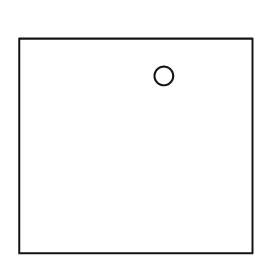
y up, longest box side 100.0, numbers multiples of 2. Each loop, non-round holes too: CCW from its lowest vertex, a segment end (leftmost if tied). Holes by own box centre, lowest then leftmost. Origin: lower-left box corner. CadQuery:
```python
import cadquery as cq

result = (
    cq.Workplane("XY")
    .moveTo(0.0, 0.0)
    .lineTo(100.0, 0.0)
    .lineTo(100.0, 92.0)
    .lineTo(0.0, 92.0)
    .close()
    .moveTo(62.0, 76.0)
    .circle(4.0)
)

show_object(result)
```